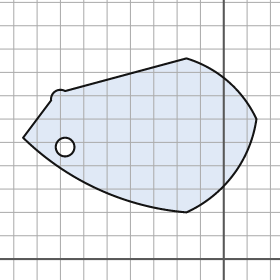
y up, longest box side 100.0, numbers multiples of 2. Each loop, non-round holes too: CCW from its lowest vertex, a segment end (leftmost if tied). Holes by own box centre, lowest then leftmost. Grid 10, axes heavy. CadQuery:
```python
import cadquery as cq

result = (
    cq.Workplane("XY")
    .moveTo(-16.0, 20.0)
    .threePointArc((4.0, 36.0), (14.0, 60.0))
    .threePointArc((2.0, 76.0), (-16.0, 86.0))
    .lineTo(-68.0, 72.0)
    .threePointArc((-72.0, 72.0), (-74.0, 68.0))
    .lineTo(-86.0, 52.0)
    .threePointArc((-54.0, 30.0), (-16.0, 20.0))
    .close()
    .moveTo(-68.0, 48.0)
    .circle(4.0)
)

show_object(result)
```